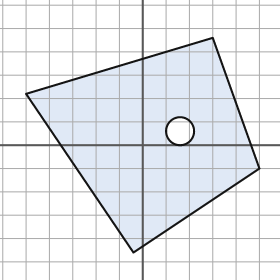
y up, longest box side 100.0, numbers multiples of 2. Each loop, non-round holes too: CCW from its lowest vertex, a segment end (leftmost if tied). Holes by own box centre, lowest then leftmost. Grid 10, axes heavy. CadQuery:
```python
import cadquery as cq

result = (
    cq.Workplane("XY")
    .moveTo(-4.0, -46.0)
    .lineTo(50.0, -10.0)
    .lineTo(30.0, 46.0)
    .lineTo(-50.0, 22.0)
    .close()
    .moveTo(16.0, 6.0)
    .circle(6.0)
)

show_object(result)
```